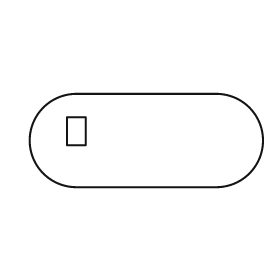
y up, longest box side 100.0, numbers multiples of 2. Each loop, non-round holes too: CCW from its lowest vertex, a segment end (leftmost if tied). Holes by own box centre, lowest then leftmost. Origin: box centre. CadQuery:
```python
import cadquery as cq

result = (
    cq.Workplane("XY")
    .moveTo(-30.0, -20.0)
    .lineTo(30.0, -20.0)
    .threePointArc((50.0, 0.0), (30.0, 20.0))
    .lineTo(-30.0, 20.0)
    .threePointArc((-50.0, 0.0), (-30.0, -20.0))
    .close()
    .moveTo(-34.0, -2.0)
    .lineTo(-26.0, -2.0)
    .lineTo(-26.0, 10.0)
    .lineTo(-34.0, 10.0)
    .close()
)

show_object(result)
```